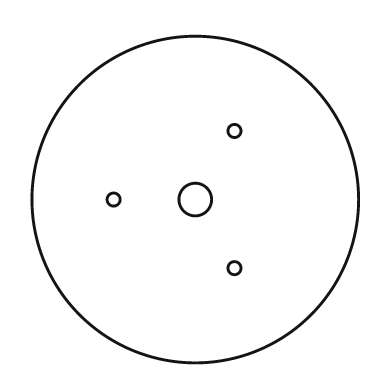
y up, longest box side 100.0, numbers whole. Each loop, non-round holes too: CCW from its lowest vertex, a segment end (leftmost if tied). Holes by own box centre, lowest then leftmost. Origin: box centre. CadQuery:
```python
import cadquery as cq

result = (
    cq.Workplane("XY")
    .moveTo(0.0, 0.0)
    .circle(50.0)
    .moveTo(12.0, -21.0)
    .circle(2.0)
    .moveTo(-25.0, 0.0)
    .circle(2.0)
    .moveTo(0.0, 0.0)
    .circle(5.0)
    .moveTo(12.0, 21.0)
    .circle(2.0)
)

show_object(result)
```